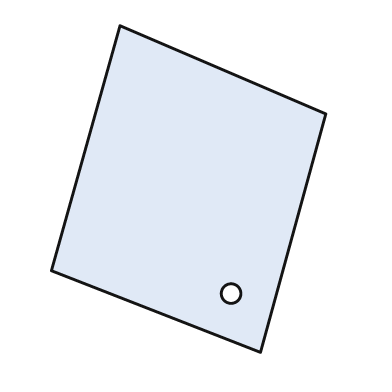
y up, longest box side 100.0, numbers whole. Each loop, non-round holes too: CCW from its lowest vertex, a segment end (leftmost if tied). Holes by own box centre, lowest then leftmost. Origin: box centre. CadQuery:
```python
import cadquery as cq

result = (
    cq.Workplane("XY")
    .moveTo(22.0, -50.0)
    .lineTo(42.0, 23.0)
    .lineTo(-21.0, 50.0)
    .lineTo(-42.0, -25.0)
    .close()
    .moveTo(13.0, -32.0)
    .circle(3.0)
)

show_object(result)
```